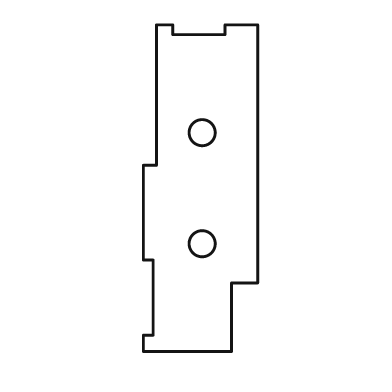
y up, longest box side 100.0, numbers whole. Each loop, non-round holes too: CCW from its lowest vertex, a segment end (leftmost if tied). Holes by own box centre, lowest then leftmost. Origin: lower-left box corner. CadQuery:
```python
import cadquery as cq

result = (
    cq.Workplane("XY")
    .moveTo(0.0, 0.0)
    .lineTo(27.0, 0.0)
    .lineTo(27.0, 21.0)
    .lineTo(35.0, 21.0)
    .lineTo(35.0, 100.0)
    .lineTo(25.0, 100.0)
    .lineTo(25.0, 97.0)
    .lineTo(9.0, 97.0)
    .lineTo(9.0, 100.0)
    .lineTo(4.0, 100.0)
    .lineTo(4.0, 57.0)
    .lineTo(0.0, 57.0)
    .lineTo(0.0, 28.0)
    .lineTo(3.0, 28.0)
    .lineTo(3.0, 5.0)
    .lineTo(0.0, 5.0)
    .close()
    .moveTo(18.0, 33.0)
    .circle(4.0)
    .moveTo(18.0, 67.0)
    .circle(4.0)
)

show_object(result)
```